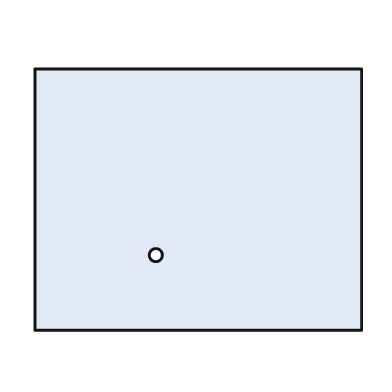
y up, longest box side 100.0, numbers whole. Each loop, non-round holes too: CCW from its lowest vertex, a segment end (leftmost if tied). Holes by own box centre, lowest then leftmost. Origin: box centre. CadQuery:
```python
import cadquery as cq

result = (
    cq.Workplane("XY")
    .moveTo(-50.0, -40.0)
    .lineTo(50.0, -40.0)
    .lineTo(50.0, 40.0)
    .lineTo(-50.0, 40.0)
    .close()
    .moveTo(-13.0, -17.0)
    .circle(2.0)
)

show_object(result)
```